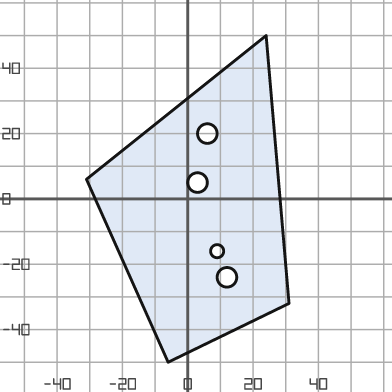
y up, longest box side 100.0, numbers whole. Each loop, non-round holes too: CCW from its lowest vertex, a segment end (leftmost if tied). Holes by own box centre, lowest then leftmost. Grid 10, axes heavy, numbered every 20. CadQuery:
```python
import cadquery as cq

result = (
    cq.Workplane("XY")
    .moveTo(-6.0, -50.0)
    .lineTo(31.0, -32.0)
    .lineTo(24.0, 50.0)
    .lineTo(-31.0, 6.0)
    .close()
    .moveTo(12.0, -24.0)
    .circle(3.0)
    .moveTo(9.0, -16.0)
    .circle(2.0)
    .moveTo(3.0, 5.0)
    .circle(3.0)
    .moveTo(6.0, 20.0)
    .circle(3.0)
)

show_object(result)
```